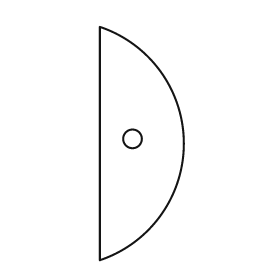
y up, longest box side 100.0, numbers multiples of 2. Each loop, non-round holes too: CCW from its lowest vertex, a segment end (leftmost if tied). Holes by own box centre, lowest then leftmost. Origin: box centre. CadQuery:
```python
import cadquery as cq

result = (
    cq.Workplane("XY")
    .moveTo(-18.0, -50.0)
    .threePointArc((18.0, 0.0), (-18.0, 50.0))
    .close()
    .moveTo(-4.0, 2.0)
    .circle(4.0)
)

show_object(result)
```